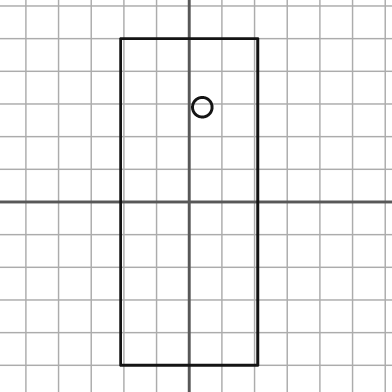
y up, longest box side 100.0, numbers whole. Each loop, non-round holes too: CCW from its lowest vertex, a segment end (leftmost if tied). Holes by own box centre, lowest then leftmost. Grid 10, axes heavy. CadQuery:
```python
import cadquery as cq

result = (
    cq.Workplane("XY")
    .moveTo(-21.0, -50.0)
    .lineTo(21.0, -50.0)
    .lineTo(21.0, 50.0)
    .lineTo(-21.0, 50.0)
    .close()
    .moveTo(4.0, 29.0)
    .circle(3.0)
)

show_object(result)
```